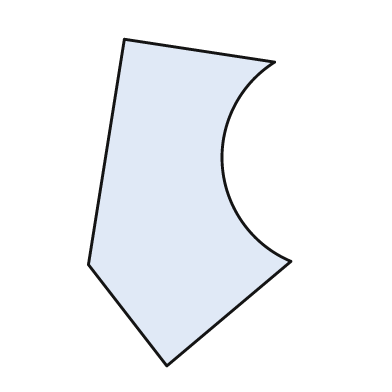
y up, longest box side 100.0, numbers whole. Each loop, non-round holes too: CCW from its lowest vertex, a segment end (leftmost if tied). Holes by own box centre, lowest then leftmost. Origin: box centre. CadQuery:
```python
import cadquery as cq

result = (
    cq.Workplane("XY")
    .moveTo(-7.0, -50.0)
    .lineTo(31.0, -18.0)
    .threePointArc((10.0, 11.0), (26.0, 43.0))
    .lineTo(-20.0, 50.0)
    .lineTo(-31.0, -19.0)
    .close()
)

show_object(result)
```